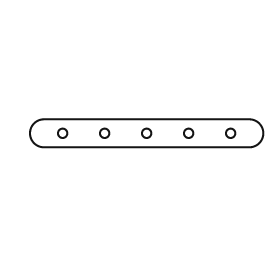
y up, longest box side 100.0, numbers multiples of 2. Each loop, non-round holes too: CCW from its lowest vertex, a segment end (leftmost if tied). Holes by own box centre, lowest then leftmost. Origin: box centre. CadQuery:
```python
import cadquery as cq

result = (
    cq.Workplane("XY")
    .moveTo(-44.0, -6.0)
    .lineTo(44.0, -6.0)
    .threePointArc((50.0, 0.0), (44.0, 6.0))
    .lineTo(-44.0, 6.0)
    .threePointArc((-50.0, 0.0), (-44.0, -6.0))
    .close()
    .moveTo(-36.0, 0.0)
    .circle(2.0)
    .moveTo(-18.0, 0.0)
    .circle(2.0)
    .moveTo(0.0, 0.0)
    .circle(2.0)
    .moveTo(18.0, 0.0)
    .circle(2.0)
    .moveTo(36.0, 0.0)
    .circle(2.0)
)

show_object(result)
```